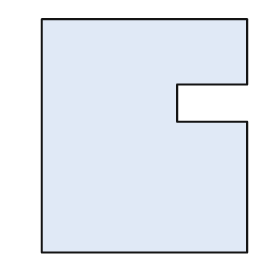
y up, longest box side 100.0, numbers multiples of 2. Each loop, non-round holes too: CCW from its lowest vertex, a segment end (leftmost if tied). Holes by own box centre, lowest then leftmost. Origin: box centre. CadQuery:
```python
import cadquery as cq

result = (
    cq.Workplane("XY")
    .moveTo(-44.0, -50.0)
    .lineTo(44.0, -50.0)
    .lineTo(44.0, 6.0)
    .lineTo(14.0, 6.0)
    .lineTo(14.0, 22.0)
    .lineTo(44.0, 22.0)
    .lineTo(44.0, 50.0)
    .lineTo(-44.0, 50.0)
    .close()
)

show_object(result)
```